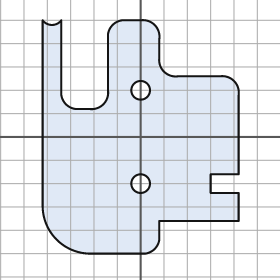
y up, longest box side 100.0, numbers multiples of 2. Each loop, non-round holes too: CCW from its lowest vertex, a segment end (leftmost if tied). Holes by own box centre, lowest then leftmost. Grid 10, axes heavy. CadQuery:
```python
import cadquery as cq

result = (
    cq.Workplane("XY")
    .moveTo(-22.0, -50.0)
    .lineTo(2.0, -50.0)
    .threePointArc((6.0, -48.0), (8.0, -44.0))
    .lineTo(8.0, -36.0)
    .lineTo(42.0, -36.0)
    .lineTo(42.0, -24.0)
    .lineTo(30.0, -24.0)
    .lineTo(30.0, -16.0)
    .lineTo(42.0, -16.0)
    .lineTo(42.0, 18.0)
    .threePointArc((40.0, 24.0), (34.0, 26.0))
    .lineTo(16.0, 26.0)
    .threePointArc((10.0, 28.0), (8.0, 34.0))
    .lineTo(8.0, 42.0)
    .threePointArc((6.0, 48.0), (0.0, 50.0))
    .lineTo(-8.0, 50.0)
    .threePointArc((-12.0, 48.0), (-14.0, 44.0))
    .lineTo(-14.0, 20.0)
    .threePointArc((-16.0, 14.0), (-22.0, 12.0))
    .lineTo(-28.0, 12.0)
    .threePointArc((-32.0, 14.0), (-34.0, 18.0))
    .lineTo(-34.0, 50.0)
    .threePointArc((-38.0, 48.0), (-42.0, 50.0))
    .lineTo(-42.0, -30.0)
    .threePointArc((-36.0, -44.0), (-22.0, -50.0))
    .close()
    .moveTo(0.0, -20.0)
    .circle(4.0)
    .moveTo(0.0, 20.0)
    .circle(4.0)
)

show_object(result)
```